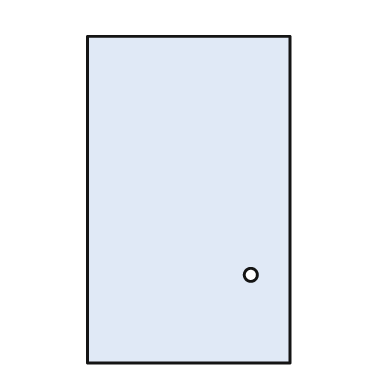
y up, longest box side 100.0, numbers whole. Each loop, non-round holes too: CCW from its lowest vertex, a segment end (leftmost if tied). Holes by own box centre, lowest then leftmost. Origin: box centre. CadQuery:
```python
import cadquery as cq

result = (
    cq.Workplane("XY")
    .moveTo(-31.0, -50.0)
    .lineTo(31.0, -50.0)
    .lineTo(31.0, 50.0)
    .lineTo(-31.0, 50.0)
    .close()
    .moveTo(19.0, -23.0)
    .circle(2.0)
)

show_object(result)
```